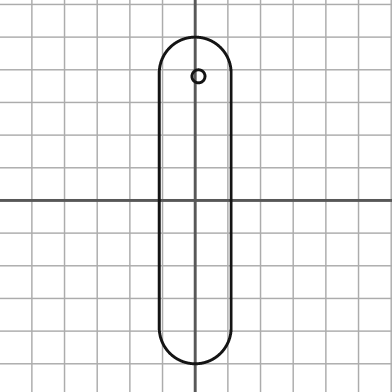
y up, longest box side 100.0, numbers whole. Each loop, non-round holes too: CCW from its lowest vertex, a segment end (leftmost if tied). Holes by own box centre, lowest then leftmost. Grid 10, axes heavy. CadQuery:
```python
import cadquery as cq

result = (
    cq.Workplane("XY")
    .moveTo(-11.0, -39.0)
    .threePointArc((0.0, -50.0), (11.0, -39.0))
    .lineTo(11.0, 39.0)
    .threePointArc((0.0, 50.0), (-11.0, 39.0))
    .close()
    .moveTo(1.0, 38.0)
    .circle(2.0)
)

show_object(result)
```